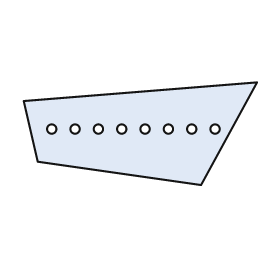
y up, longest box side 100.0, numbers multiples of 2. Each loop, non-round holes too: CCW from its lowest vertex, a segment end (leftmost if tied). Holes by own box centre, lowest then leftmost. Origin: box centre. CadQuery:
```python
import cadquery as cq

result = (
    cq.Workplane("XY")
    .moveTo(26.0, -22.0)
    .lineTo(50.0, 22.0)
    .lineTo(-50.0, 14.0)
    .lineTo(-44.0, -12.0)
    .close()
    .moveTo(-38.0, 2.0)
    .circle(2.0)
    .moveTo(-28.0, 2.0)
    .circle(2.0)
    .moveTo(-18.0, 2.0)
    .circle(2.0)
    .moveTo(-8.0, 2.0)
    .circle(2.0)
    .moveTo(2.0, 2.0)
    .circle(2.0)
    .moveTo(12.0, 2.0)
    .circle(2.0)
    .moveTo(22.0, 2.0)
    .circle(2.0)
    .moveTo(32.0, 2.0)
    .circle(2.0)
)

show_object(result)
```